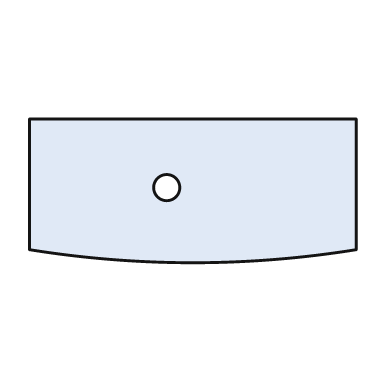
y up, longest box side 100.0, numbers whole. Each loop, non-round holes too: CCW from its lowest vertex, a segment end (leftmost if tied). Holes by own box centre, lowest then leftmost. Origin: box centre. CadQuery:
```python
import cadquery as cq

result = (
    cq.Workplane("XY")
    .moveTo(-50.0, -18.0)
    .threePointArc((0.0, -22.0), (50.0, -18.0))
    .lineTo(50.0, 22.0)
    .lineTo(-50.0, 22.0)
    .close()
    .moveTo(-8.0, 1.0)
    .circle(4.0)
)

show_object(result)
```